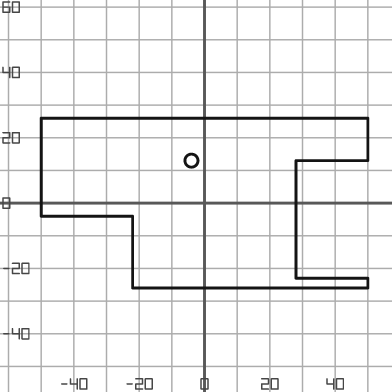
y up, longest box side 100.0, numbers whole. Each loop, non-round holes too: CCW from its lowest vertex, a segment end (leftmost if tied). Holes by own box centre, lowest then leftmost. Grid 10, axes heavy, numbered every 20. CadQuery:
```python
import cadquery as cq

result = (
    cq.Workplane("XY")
    .moveTo(-22.0, -26.0)
    .lineTo(50.0, -26.0)
    .lineTo(50.0, -23.0)
    .lineTo(28.0, -23.0)
    .lineTo(28.0, 13.0)
    .lineTo(50.0, 13.0)
    .lineTo(50.0, 26.0)
    .lineTo(-50.0, 26.0)
    .lineTo(-50.0, -4.0)
    .lineTo(-22.0, -4.0)
    .close()
    .moveTo(-4.0, 13.0)
    .circle(2.0)
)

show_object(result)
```